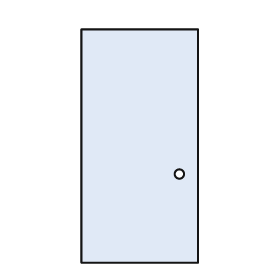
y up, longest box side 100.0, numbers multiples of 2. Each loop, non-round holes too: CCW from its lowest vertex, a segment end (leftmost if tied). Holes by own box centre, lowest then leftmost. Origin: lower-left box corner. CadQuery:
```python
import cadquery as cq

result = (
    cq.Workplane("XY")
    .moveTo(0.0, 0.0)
    .lineTo(50.0, 0.0)
    .lineTo(50.0, 100.0)
    .lineTo(0.0, 100.0)
    .close()
    .moveTo(42.0, 38.0)
    .circle(2.0)
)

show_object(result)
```